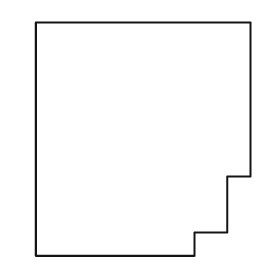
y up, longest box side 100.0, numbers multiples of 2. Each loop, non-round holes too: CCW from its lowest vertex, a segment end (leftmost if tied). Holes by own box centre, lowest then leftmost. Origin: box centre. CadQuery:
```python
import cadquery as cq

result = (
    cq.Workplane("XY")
    .moveTo(-46.0, -50.0)
    .lineTo(22.0, -50.0)
    .lineTo(22.0, -40.0)
    .lineTo(36.0, -40.0)
    .lineTo(36.0, -16.0)
    .lineTo(46.0, -16.0)
    .lineTo(46.0, 50.0)
    .lineTo(-46.0, 50.0)
    .close()
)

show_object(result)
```